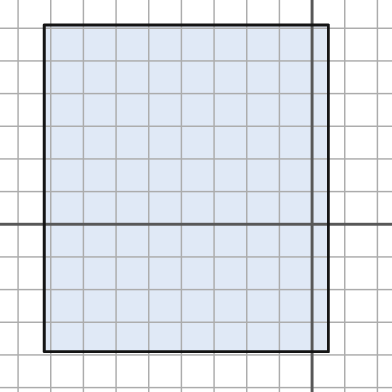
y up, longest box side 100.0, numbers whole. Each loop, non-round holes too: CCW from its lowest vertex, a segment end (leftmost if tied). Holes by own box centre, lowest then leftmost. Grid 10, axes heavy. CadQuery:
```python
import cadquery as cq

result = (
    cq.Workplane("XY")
    .moveTo(-82.0, -39.0)
    .lineTo(5.0, -39.0)
    .lineTo(5.0, 61.0)
    .lineTo(-82.0, 61.0)
    .close()
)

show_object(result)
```